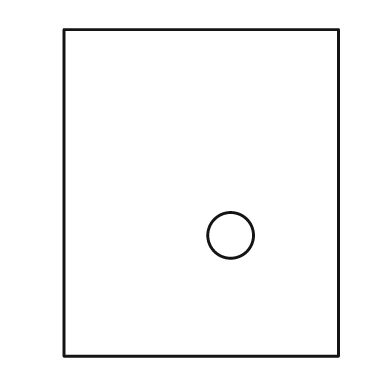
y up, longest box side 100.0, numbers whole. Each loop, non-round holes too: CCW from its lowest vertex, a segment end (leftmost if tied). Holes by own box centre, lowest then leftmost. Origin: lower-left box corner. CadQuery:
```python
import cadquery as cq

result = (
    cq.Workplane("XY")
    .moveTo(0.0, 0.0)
    .lineTo(84.0, 0.0)
    .lineTo(84.0, 100.0)
    .lineTo(0.0, 100.0)
    .close()
    .moveTo(51.0, 37.0)
    .circle(7.0)
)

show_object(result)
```